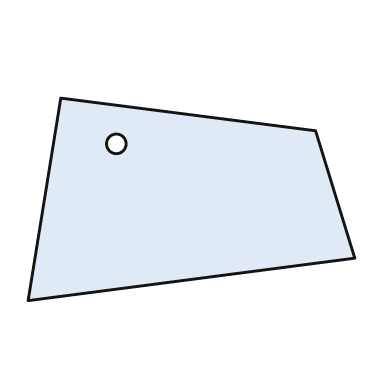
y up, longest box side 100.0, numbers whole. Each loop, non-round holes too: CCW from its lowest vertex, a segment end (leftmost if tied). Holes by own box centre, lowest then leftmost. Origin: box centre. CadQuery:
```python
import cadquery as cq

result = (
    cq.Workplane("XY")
    .moveTo(-50.0, -31.0)
    .lineTo(50.0, -18.0)
    .lineTo(38.0, 21.0)
    .lineTo(-40.0, 31.0)
    .close()
    .moveTo(-23.0, 17.0)
    .circle(3.0)
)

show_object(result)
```